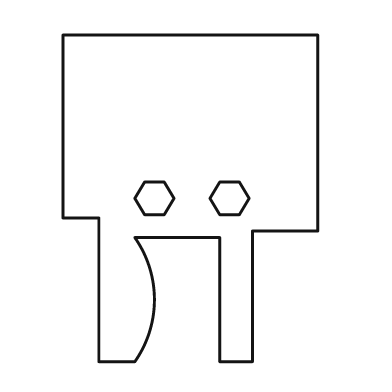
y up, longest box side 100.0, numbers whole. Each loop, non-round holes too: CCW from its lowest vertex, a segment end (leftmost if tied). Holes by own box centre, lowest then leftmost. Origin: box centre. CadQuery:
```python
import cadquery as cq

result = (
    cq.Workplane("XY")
    .moveTo(-28.0, -50.0)
    .lineTo(-17.0, -50.0)
    .threePointArc((-11.0, -31.0), (-17.0, -12.0))
    .lineTo(9.0, -12.0)
    .lineTo(9.0, -50.0)
    .lineTo(19.0, -50.0)
    .lineTo(19.0, -10.0)
    .lineTo(39.0, -10.0)
    .lineTo(39.0, 50.0)
    .lineTo(-39.0, 50.0)
    .lineTo(-39.0, -6.0)
    .lineTo(-28.0, -6.0)
    .close()
    .moveTo(-14.0, -5.0)
    .lineTo(-8.0, -5.0)
    .lineTo(-5.0, 0.0)
    .lineTo(-8.0, 5.0)
    .lineTo(-14.0, 5.0)
    .lineTo(-17.0, 0.0)
    .close()
    .moveTo(9.0, -5.0)
    .lineTo(15.0, -5.0)
    .lineTo(18.0, 0.0)
    .lineTo(15.0, 5.0)
    .lineTo(9.0, 5.0)
    .lineTo(6.0, 0.0)
    .close()
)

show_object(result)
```